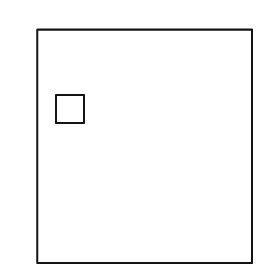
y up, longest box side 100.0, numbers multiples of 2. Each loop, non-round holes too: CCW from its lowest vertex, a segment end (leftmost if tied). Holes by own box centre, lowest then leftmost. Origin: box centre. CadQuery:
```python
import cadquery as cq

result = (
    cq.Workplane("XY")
    .moveTo(-46.0, -50.0)
    .lineTo(46.0, -50.0)
    .lineTo(46.0, 50.0)
    .lineTo(-46.0, 50.0)
    .close()
    .moveTo(-38.0, 10.0)
    .lineTo(-26.0, 10.0)
    .lineTo(-26.0, 22.0)
    .lineTo(-38.0, 22.0)
    .close()
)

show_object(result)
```